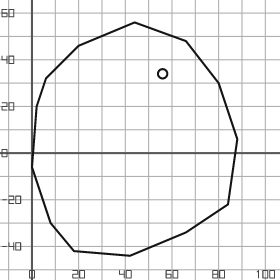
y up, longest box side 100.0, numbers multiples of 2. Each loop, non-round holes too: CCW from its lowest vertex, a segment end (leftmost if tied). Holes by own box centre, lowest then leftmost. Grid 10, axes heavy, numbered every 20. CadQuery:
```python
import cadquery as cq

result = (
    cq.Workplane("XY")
    .moveTo(42.0, -44.0)
    .lineTo(66.0, -34.0)
    .lineTo(84.0, -22.0)
    .lineTo(88.0, 6.0)
    .lineTo(80.0, 30.0)
    .lineTo(66.0, 48.0)
    .lineTo(44.0, 56.0)
    .lineTo(20.0, 46.0)
    .lineTo(6.0, 32.0)
    .lineTo(2.0, 20.0)
    .lineTo(0.0, -6.0)
    .lineTo(8.0, -30.0)
    .lineTo(18.0, -42.0)
    .close()
    .moveTo(56.0, 34.0)
    .circle(2.0)
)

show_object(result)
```